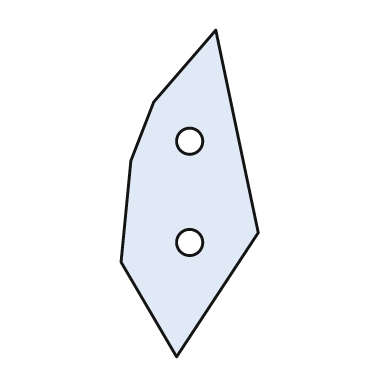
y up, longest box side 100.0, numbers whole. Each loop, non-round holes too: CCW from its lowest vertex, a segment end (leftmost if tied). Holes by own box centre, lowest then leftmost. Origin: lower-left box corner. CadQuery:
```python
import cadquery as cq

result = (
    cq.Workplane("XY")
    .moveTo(17.0, 0.0)
    .lineTo(42.0, 38.0)
    .lineTo(29.0, 100.0)
    .lineTo(10.0, 78.0)
    .lineTo(3.0, 60.0)
    .lineTo(0.0, 29.0)
    .close()
    .moveTo(21.0, 35.0)
    .circle(4.0)
    .moveTo(21.0, 66.0)
    .circle(4.0)
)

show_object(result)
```